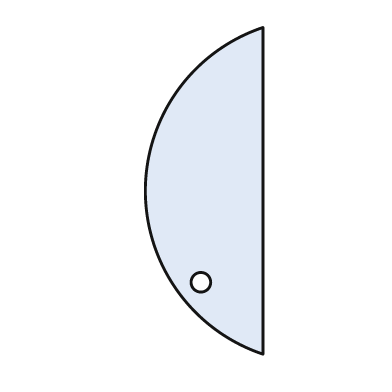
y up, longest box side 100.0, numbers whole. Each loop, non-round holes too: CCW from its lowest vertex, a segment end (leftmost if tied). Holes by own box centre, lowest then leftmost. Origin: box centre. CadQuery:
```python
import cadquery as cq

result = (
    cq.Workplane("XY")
    .moveTo(18.0, -50.0)
    .lineTo(18.0, 50.0)
    .threePointArc((-18.0, 0.0), (18.0, -50.0))
    .close()
    .moveTo(-1.0, -28.0)
    .circle(3.0)
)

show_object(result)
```